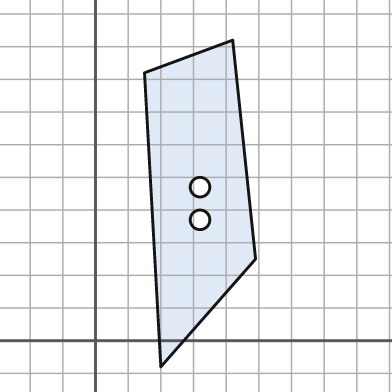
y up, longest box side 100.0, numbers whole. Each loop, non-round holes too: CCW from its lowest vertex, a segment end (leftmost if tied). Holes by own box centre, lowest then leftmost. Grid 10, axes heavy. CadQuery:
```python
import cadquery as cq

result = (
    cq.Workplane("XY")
    .moveTo(20.0, -8.0)
    .lineTo(49.0, 25.0)
    .lineTo(42.0, 92.0)
    .lineTo(15.0, 82.0)
    .close()
    .moveTo(32.0, 37.0)
    .circle(3.0)
    .moveTo(32.0, 47.0)
    .circle(3.0)
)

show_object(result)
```